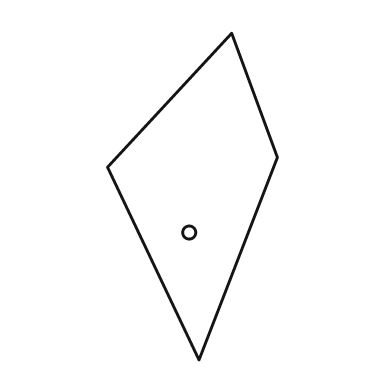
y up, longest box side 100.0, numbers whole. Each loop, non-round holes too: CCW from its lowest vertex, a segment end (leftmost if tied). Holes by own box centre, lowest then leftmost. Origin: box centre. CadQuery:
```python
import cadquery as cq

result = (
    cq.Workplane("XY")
    .moveTo(2.0, -50.0)
    .lineTo(26.0, 12.0)
    .lineTo(12.0, 50.0)
    .lineTo(-26.0, 9.0)
    .close()
    .moveTo(-1.0, -11.0)
    .circle(2.0)
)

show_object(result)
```